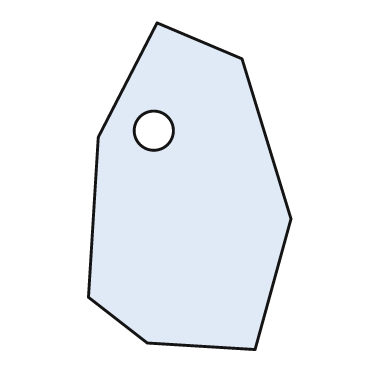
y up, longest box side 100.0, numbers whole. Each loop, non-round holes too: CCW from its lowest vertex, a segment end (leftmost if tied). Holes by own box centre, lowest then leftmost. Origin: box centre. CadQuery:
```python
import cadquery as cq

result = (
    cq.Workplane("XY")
    .moveTo(20.0, -50.0)
    .lineTo(31.0, -10.0)
    .lineTo(16.0, 39.0)
    .lineTo(-10.0, 50.0)
    .lineTo(-28.0, 15.0)
    .lineTo(-31.0, -34.0)
    .lineTo(-13.0, -48.0)
    .close()
    .moveTo(-11.0, 17.0)
    .circle(6.0)
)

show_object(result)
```